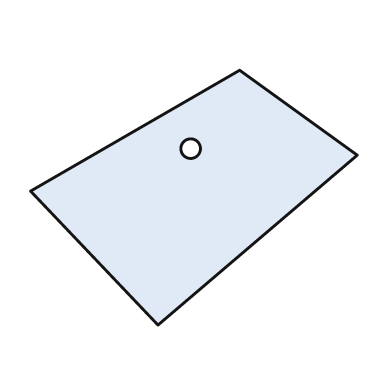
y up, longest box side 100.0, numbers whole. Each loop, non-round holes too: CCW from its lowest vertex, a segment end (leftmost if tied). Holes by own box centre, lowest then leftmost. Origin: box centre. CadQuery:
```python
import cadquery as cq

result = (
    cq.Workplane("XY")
    .moveTo(-11.0, -39.0)
    .lineTo(50.0, 13.0)
    .lineTo(14.0, 39.0)
    .lineTo(-50.0, 2.0)
    .close()
    .moveTo(-1.0, 15.0)
    .circle(3.0)
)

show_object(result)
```